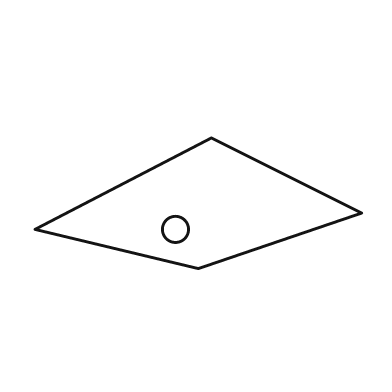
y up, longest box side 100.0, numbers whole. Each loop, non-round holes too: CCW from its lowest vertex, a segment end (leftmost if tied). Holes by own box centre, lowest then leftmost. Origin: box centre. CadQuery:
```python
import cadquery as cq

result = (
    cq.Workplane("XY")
    .moveTo(0.0, -20.0)
    .lineTo(50.0, -3.0)
    .lineTo(4.0, 20.0)
    .lineTo(-50.0, -8.0)
    .close()
    .moveTo(-7.0, -8.0)
    .circle(4.0)
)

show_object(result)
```